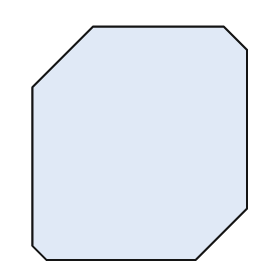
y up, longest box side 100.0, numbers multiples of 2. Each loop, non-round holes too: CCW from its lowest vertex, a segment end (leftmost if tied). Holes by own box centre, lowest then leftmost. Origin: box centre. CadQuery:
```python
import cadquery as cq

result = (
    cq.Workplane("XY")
    .moveTo(-40.0, -50.0)
    .lineTo(24.0, -50.0)
    .lineTo(46.0, -28.0)
    .lineTo(46.0, 40.0)
    .lineTo(36.0, 50.0)
    .lineTo(-20.0, 50.0)
    .lineTo(-46.0, 24.0)
    .lineTo(-46.0, -44.0)
    .close()
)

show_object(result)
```